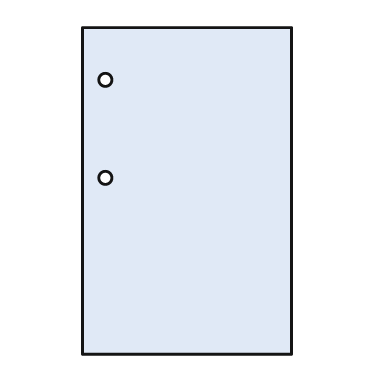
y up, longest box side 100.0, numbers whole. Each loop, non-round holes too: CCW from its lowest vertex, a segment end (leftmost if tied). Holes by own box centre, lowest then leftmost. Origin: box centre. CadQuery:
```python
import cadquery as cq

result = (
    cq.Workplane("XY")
    .moveTo(-32.0, -50.0)
    .lineTo(32.0, -50.0)
    .lineTo(32.0, 50.0)
    .lineTo(-32.0, 50.0)
    .close()
    .moveTo(-25.0, 4.0)
    .circle(2.0)
    .moveTo(-25.0, 34.0)
    .circle(2.0)
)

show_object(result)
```